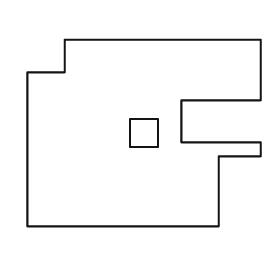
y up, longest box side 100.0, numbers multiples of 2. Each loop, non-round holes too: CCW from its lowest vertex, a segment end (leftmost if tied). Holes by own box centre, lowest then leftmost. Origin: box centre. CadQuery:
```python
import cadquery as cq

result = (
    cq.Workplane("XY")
    .moveTo(-50.0, -40.0)
    .lineTo(32.0, -40.0)
    .lineTo(32.0, -10.0)
    .lineTo(50.0, -10.0)
    .lineTo(50.0, -4.0)
    .lineTo(16.0, -4.0)
    .lineTo(16.0, 14.0)
    .lineTo(50.0, 14.0)
    .lineTo(50.0, 40.0)
    .lineTo(-34.0, 40.0)
    .lineTo(-34.0, 26.0)
    .lineTo(-50.0, 26.0)
    .close()
    .moveTo(-6.0, -6.0)
    .lineTo(6.0, -6.0)
    .lineTo(6.0, 6.0)
    .lineTo(-6.0, 6.0)
    .close()
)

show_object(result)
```